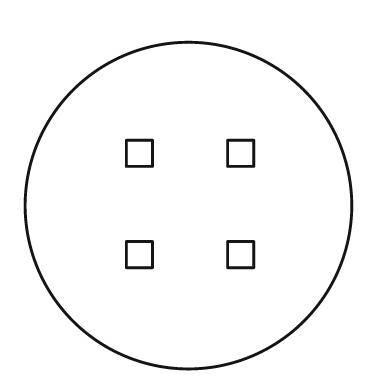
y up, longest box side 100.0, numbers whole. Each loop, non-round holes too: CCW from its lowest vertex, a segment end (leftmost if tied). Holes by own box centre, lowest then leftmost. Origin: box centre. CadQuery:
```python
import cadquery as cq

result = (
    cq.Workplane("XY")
    .moveTo(0.0, 0.0)
    .circle(50.0)
    .moveTo(-19.0, -19.0)
    .lineTo(-11.0, -19.0)
    .lineTo(-11.0, -11.0)
    .lineTo(-19.0, -11.0)
    .close()
    .moveTo(12.0, -19.0)
    .lineTo(20.0, -19.0)
    .lineTo(20.0, -11.0)
    .lineTo(12.0, -11.0)
    .close()
    .moveTo(-19.0, 12.0)
    .lineTo(-11.0, 12.0)
    .lineTo(-11.0, 20.0)
    .lineTo(-19.0, 20.0)
    .close()
    .moveTo(12.0, 12.0)
    .lineTo(20.0, 12.0)
    .lineTo(20.0, 20.0)
    .lineTo(12.0, 20.0)
    .close()
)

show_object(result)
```